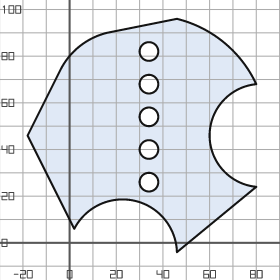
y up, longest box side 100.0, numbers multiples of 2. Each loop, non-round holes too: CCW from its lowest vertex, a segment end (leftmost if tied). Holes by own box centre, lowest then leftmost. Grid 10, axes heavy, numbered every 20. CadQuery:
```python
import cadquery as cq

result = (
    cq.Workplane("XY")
    .moveTo(46.0, -4.0)
    .lineTo(80.0, 24.0)
    .threePointArc((60.0, 46.0), (80.0, 68.0))
    .threePointArc((66.0, 86.0), (46.0, 96.0))
    .lineTo(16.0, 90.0)
    .threePointArc((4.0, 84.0), (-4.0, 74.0))
    .lineTo(-18.0, 46.0)
    .lineTo(2.0, 6.0)
    .threePointArc((28.0, 18.0), (46.0, -4.0))
    .close()
    .moveTo(34.0, 26.0)
    .circle(4.0)
    .moveTo(34.0, 40.0)
    .circle(4.0)
    .moveTo(34.0, 54.0)
    .circle(4.0)
    .moveTo(34.0, 68.0)
    .circle(4.0)
    .moveTo(34.0, 82.0)
    .circle(4.0)
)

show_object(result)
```